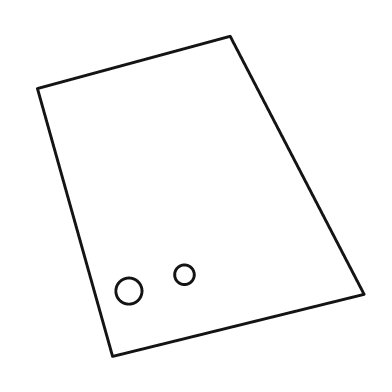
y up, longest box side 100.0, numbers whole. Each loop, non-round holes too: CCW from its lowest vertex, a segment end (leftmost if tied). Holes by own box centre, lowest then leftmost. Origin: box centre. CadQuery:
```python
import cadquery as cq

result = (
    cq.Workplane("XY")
    .moveTo(-27.0, -49.0)
    .lineTo(50.0, -30.0)
    .lineTo(9.0, 49.0)
    .lineTo(-50.0, 33.0)
    .close()
    .moveTo(-22.0, -29.0)
    .circle(4.0)
    .moveTo(-5.0, -24.0)
    .circle(3.0)
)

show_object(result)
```